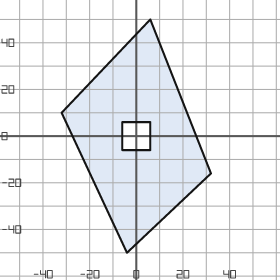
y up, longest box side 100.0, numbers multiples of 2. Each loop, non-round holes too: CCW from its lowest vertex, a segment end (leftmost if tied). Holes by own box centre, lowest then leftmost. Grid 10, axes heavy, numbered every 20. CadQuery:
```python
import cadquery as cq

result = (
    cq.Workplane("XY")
    .moveTo(-4.0, -50.0)
    .lineTo(32.0, -16.0)
    .lineTo(6.0, 50.0)
    .lineTo(-32.0, 10.0)
    .close()
    .moveTo(-6.0, -6.0)
    .lineTo(6.0, -6.0)
    .lineTo(6.0, 6.0)
    .lineTo(-6.0, 6.0)
    .close()
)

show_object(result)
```